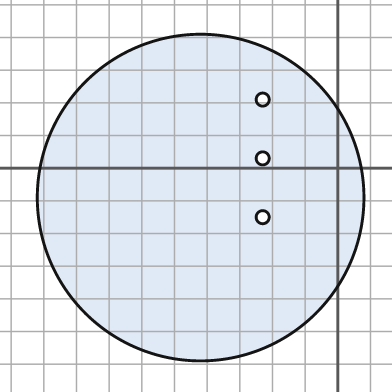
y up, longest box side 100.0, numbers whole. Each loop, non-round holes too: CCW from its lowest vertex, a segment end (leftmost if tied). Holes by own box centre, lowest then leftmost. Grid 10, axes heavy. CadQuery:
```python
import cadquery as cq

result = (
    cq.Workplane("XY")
    .moveTo(-42.0, -9.0)
    .circle(50.0)
    .moveTo(-23.0, -15.0)
    .circle(2.0)
    .moveTo(-23.0, 3.0)
    .circle(2.0)
    .moveTo(-23.0, 21.0)
    .circle(2.0)
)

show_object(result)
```